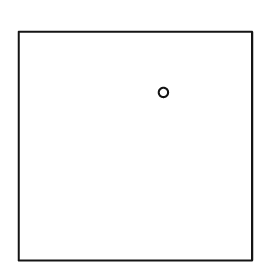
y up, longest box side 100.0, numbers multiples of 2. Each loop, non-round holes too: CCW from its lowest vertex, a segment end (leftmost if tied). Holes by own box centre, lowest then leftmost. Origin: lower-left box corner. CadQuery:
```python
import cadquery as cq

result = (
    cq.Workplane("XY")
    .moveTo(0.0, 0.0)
    .lineTo(100.0, 0.0)
    .lineTo(100.0, 98.0)
    .lineTo(0.0, 98.0)
    .close()
    .moveTo(62.0, 72.0)
    .circle(2.0)
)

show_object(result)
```